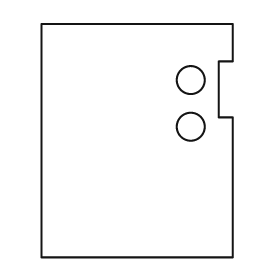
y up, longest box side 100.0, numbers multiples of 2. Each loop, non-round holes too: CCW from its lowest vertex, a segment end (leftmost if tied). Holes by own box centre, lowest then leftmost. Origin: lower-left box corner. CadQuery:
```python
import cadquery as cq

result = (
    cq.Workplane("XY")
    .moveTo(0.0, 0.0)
    .lineTo(82.0, 0.0)
    .lineTo(82.0, 60.0)
    .lineTo(76.0, 60.0)
    .lineTo(76.0, 84.0)
    .lineTo(82.0, 84.0)
    .lineTo(82.0, 100.0)
    .lineTo(0.0, 100.0)
    .close()
    .moveTo(64.0, 56.0)
    .circle(6.0)
    .moveTo(64.0, 76.0)
    .circle(6.0)
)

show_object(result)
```